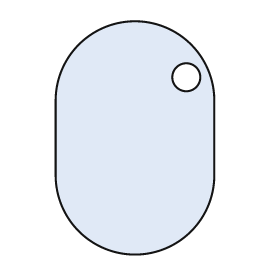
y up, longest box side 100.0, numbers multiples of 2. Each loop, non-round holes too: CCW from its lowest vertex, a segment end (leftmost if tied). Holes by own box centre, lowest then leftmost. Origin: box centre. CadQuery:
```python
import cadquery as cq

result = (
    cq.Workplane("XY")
    .moveTo(-34.0, -16.0)
    .threePointArc((0.0, -50.0), (34.0, -16.0))
    .lineTo(34.0, 16.0)
    .threePointArc((0.0, 50.0), (-34.0, 16.0))
    .close()
    .moveTo(22.0, 26.0)
    .circle(6.0)
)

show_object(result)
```